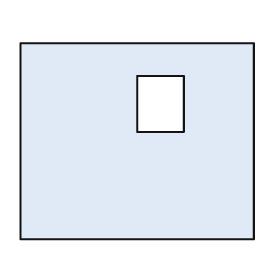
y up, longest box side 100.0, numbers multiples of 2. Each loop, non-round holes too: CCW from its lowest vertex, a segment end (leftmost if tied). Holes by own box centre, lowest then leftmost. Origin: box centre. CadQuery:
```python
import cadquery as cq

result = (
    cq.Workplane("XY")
    .moveTo(-50.0, -42.0)
    .lineTo(50.0, -42.0)
    .lineTo(50.0, 42.0)
    .lineTo(-50.0, 42.0)
    .close()
    .moveTo(0.0, 4.0)
    .lineTo(20.0, 4.0)
    .lineTo(20.0, 28.0)
    .lineTo(0.0, 28.0)
    .close()
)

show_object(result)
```